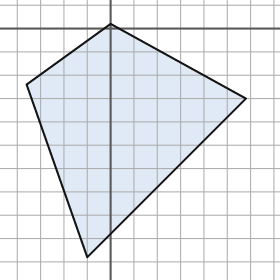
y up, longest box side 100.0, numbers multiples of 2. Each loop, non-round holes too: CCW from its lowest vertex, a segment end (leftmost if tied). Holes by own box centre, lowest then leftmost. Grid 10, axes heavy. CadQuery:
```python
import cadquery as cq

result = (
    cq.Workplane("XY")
    .moveTo(-10.0, -98.0)
    .lineTo(58.0, -30.0)
    .lineTo(0.0, 2.0)
    .lineTo(-36.0, -24.0)
    .close()
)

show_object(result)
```